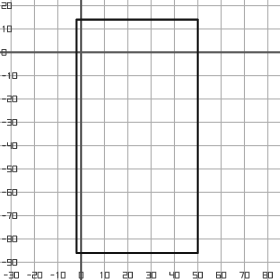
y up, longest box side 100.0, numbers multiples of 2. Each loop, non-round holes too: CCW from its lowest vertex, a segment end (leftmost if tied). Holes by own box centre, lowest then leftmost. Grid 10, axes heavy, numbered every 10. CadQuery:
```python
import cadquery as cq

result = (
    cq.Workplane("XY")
    .moveTo(-2.0, -86.0)
    .lineTo(50.0, -86.0)
    .lineTo(50.0, 14.0)
    .lineTo(-2.0, 14.0)
    .close()
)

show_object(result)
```